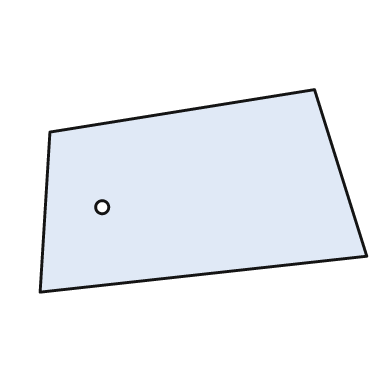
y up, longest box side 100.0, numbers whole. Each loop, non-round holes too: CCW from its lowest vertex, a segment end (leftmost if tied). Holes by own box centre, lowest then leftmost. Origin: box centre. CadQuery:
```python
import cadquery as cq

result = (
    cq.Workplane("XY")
    .moveTo(-50.0, -31.0)
    .lineTo(50.0, -20.0)
    .lineTo(34.0, 31.0)
    .lineTo(-47.0, 18.0)
    .close()
    .moveTo(-31.0, -5.0)
    .circle(2.0)
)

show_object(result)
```